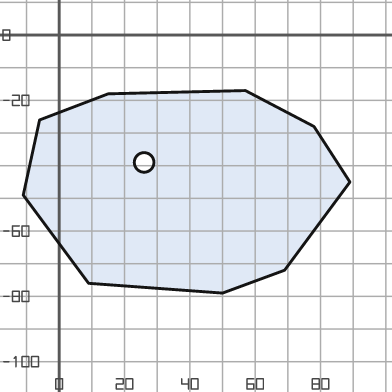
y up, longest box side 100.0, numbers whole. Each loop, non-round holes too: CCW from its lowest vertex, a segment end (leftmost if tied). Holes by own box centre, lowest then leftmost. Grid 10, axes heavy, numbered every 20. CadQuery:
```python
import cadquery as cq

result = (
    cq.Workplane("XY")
    .moveTo(50.0, -79.0)
    .lineTo(69.0, -72.0)
    .lineTo(89.0, -45.0)
    .lineTo(78.0, -28.0)
    .lineTo(57.0, -17.0)
    .lineTo(15.0, -18.0)
    .lineTo(-6.0, -26.0)
    .lineTo(-11.0, -49.0)
    .lineTo(9.0, -76.0)
    .close()
    .moveTo(26.0, -39.0)
    .circle(3.0)
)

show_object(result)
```